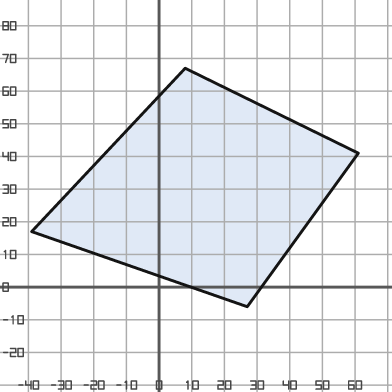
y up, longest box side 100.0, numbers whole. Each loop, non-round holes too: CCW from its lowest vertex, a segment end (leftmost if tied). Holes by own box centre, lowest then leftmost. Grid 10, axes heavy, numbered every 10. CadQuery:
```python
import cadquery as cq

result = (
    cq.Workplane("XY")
    .moveTo(27.0, -6.0)
    .lineTo(61.0, 41.0)
    .lineTo(8.0, 67.0)
    .lineTo(-39.0, 17.0)
    .close()
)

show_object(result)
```